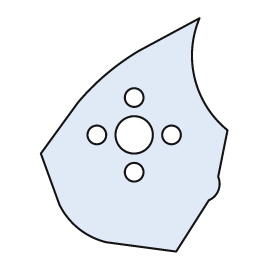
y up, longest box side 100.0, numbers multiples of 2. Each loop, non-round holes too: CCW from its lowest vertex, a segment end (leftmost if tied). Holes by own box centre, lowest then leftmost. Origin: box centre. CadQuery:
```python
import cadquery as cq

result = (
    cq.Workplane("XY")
    .moveTo(18.0, -50.0)
    .lineTo(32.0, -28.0)
    .threePointArc((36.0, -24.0), (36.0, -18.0))
    .lineTo(40.0, 2.0)
    .threePointArc((26.0, 24.0), (28.0, 50.0))
    .lineTo(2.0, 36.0)
    .threePointArc((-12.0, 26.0), (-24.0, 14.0))
    .lineTo(-40.0, -8.0)
    .lineTo(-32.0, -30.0)
    .threePointArc((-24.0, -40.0), (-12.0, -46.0))
    .close()
    .moveTo(0.0, -16.0)
    .circle(4.0)
    .moveTo(-16.0, 0.0)
    .circle(4.0)
    .moveTo(0.0, 0.0)
    .circle(8.0)
    .moveTo(16.0, 0.0)
    .circle(4.0)
    .moveTo(0.0, 16.0)
    .circle(4.0)
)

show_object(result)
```